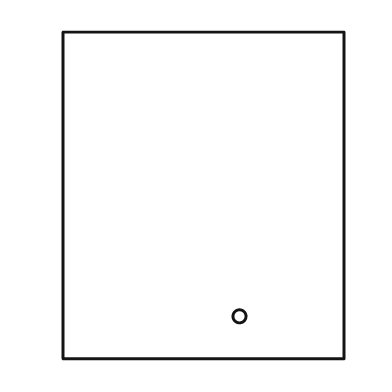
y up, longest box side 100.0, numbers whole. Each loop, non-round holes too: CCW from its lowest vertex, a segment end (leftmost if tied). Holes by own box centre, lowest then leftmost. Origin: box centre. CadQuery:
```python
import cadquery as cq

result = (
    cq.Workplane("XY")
    .moveTo(-43.0, -50.0)
    .lineTo(43.0, -50.0)
    .lineTo(43.0, 50.0)
    .lineTo(-43.0, 50.0)
    .close()
    .moveTo(11.0, -37.0)
    .circle(2.0)
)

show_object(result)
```